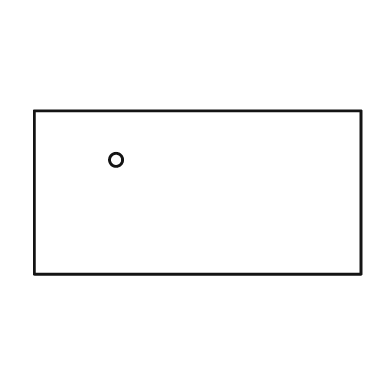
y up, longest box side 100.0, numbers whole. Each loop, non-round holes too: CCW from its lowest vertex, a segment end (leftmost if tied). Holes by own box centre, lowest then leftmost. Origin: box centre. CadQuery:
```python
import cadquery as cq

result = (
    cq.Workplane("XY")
    .moveTo(-50.0, -25.0)
    .lineTo(50.0, -25.0)
    .lineTo(50.0, 25.0)
    .lineTo(-50.0, 25.0)
    .close()
    .moveTo(-25.0, 10.0)
    .circle(2.0)
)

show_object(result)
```